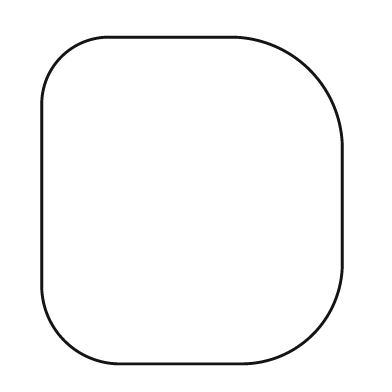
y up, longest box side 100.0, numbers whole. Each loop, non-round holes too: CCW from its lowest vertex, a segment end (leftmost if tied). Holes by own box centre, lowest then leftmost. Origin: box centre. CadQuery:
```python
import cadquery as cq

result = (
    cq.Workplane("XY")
    .moveTo(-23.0, -50.0)
    .lineTo(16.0, -50.0)
    .threePointArc((37.0, -41.0), (46.0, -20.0))
    .lineTo(46.0, 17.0)
    .threePointArc((36.0, 40.0), (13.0, 50.0))
    .lineTo(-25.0, 50.0)
    .threePointArc((-40.0, 44.0), (-46.0, 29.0))
    .lineTo(-46.0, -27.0)
    .threePointArc((-39.0, -43.0), (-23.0, -50.0))
    .close()
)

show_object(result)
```